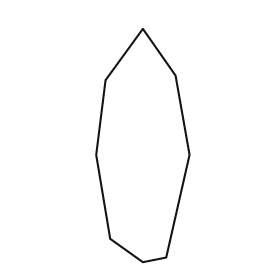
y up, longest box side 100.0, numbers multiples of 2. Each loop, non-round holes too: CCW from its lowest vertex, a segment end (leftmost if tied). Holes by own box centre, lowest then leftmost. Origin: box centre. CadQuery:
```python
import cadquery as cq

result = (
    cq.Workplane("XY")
    .moveTo(0.0, -50.0)
    .lineTo(10.0, -48.0)
    .lineTo(20.0, -4.0)
    .lineTo(14.0, 30.0)
    .lineTo(0.0, 50.0)
    .lineTo(-16.0, 28.0)
    .lineTo(-20.0, -4.0)
    .lineTo(-14.0, -40.0)
    .close()
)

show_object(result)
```